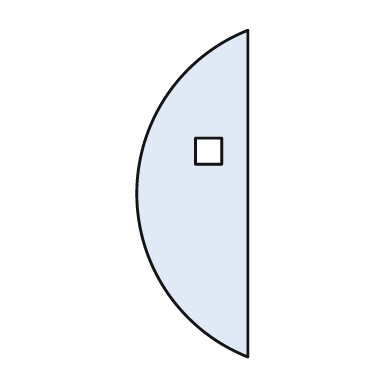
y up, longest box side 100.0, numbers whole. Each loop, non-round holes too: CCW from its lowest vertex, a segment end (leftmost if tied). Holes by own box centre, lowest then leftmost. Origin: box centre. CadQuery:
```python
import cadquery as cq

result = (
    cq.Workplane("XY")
    .moveTo(17.0, -50.0)
    .lineTo(17.0, 50.0)
    .threePointArc((-17.0, 0.0), (17.0, -50.0))
    .close()
    .moveTo(1.0, 9.0)
    .lineTo(9.0, 9.0)
    .lineTo(9.0, 17.0)
    .lineTo(1.0, 17.0)
    .close()
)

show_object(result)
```